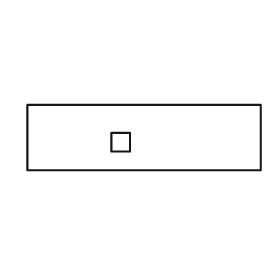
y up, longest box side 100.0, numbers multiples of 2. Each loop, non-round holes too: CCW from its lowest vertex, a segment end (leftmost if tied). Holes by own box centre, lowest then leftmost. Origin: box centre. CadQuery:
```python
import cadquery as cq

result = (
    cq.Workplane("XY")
    .moveTo(-50.0, -14.0)
    .lineTo(50.0, -14.0)
    .lineTo(50.0, 14.0)
    .lineTo(-50.0, 14.0)
    .close()
    .moveTo(-14.0, -6.0)
    .lineTo(-6.0, -6.0)
    .lineTo(-6.0, 2.0)
    .lineTo(-14.0, 2.0)
    .close()
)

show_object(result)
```